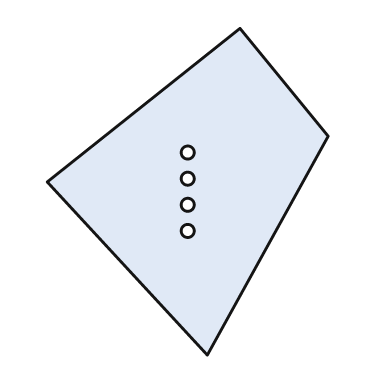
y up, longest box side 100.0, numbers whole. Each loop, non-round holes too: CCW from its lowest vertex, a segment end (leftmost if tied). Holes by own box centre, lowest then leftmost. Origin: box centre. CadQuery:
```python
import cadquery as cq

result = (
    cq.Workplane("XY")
    .moveTo(6.0, -50.0)
    .lineTo(43.0, 17.0)
    .lineTo(16.0, 50.0)
    .lineTo(-43.0, 3.0)
    .close()
    .moveTo(0.0, -12.0)
    .circle(2.0)
    .moveTo(0.0, -4.0)
    .circle(2.0)
    .moveTo(0.0, 4.0)
    .circle(2.0)
    .moveTo(0.0, 12.0)
    .circle(2.0)
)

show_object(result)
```